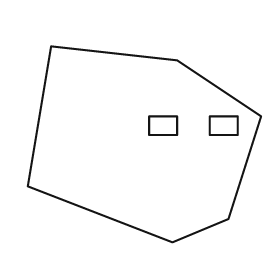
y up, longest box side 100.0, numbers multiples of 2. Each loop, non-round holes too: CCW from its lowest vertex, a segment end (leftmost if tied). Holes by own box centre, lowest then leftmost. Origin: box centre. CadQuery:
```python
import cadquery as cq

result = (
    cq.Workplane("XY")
    .moveTo(12.0, -42.0)
    .lineTo(36.0, -32.0)
    .lineTo(50.0, 12.0)
    .lineTo(14.0, 36.0)
    .lineTo(-40.0, 42.0)
    .lineTo(-50.0, -18.0)
    .close()
    .moveTo(2.0, 4.0)
    .lineTo(14.0, 4.0)
    .lineTo(14.0, 12.0)
    .lineTo(2.0, 12.0)
    .close()
    .moveTo(28.0, 4.0)
    .lineTo(40.0, 4.0)
    .lineTo(40.0, 12.0)
    .lineTo(28.0, 12.0)
    .close()
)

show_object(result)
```